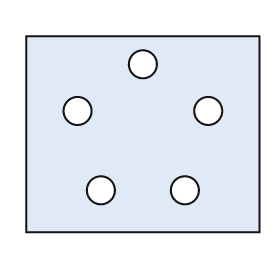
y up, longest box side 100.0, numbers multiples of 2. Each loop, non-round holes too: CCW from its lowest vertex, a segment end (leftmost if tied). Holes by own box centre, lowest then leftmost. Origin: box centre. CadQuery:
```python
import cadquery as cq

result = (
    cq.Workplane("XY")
    .moveTo(-50.0, -42.0)
    .lineTo(50.0, -42.0)
    .lineTo(50.0, 42.0)
    .lineTo(-50.0, 42.0)
    .close()
    .moveTo(-18.0, -24.0)
    .circle(6.0)
    .moveTo(18.0, -24.0)
    .circle(6.0)
    .moveTo(-28.0, 10.0)
    .circle(6.0)
    .moveTo(28.0, 10.0)
    .circle(6.0)
    .moveTo(0.0, 30.0)
    .circle(6.0)
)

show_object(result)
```